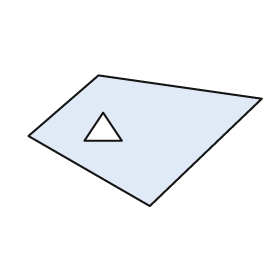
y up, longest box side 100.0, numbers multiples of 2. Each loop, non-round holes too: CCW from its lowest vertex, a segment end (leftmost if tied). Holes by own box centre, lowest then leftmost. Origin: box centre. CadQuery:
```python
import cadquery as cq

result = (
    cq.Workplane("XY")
    .moveTo(2.0, -28.0)
    .lineTo(50.0, 18.0)
    .lineTo(-20.0, 28.0)
    .lineTo(-50.0, 2.0)
    .close()
    .moveTo(-26.0, 0.0)
    .lineTo(-10.0, 0.0)
    .lineTo(-18.0, 12.0)
    .close()
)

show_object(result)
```